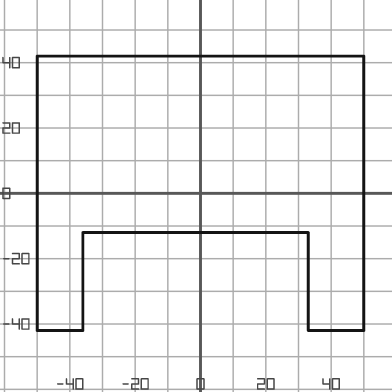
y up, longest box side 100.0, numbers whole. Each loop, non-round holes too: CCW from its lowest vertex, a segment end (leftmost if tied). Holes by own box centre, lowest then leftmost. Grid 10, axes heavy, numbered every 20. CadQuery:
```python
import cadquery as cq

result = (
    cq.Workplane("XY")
    .moveTo(-50.0, -42.0)
    .lineTo(-36.0, -42.0)
    .lineTo(-36.0, -12.0)
    .lineTo(33.0, -12.0)
    .lineTo(33.0, -42.0)
    .lineTo(50.0, -42.0)
    .lineTo(50.0, 42.0)
    .lineTo(-50.0, 42.0)
    .close()
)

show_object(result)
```